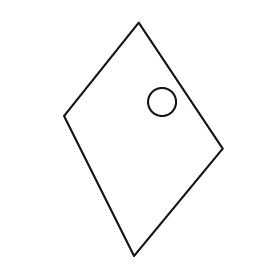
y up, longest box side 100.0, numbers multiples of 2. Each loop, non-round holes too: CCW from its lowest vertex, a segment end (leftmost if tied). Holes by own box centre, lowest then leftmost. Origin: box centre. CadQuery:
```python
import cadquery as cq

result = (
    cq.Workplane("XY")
    .moveTo(-4.0, -50.0)
    .lineTo(34.0, -4.0)
    .lineTo(-2.0, 50.0)
    .lineTo(-34.0, 10.0)
    .close()
    .moveTo(8.0, 16.0)
    .circle(6.0)
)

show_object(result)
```